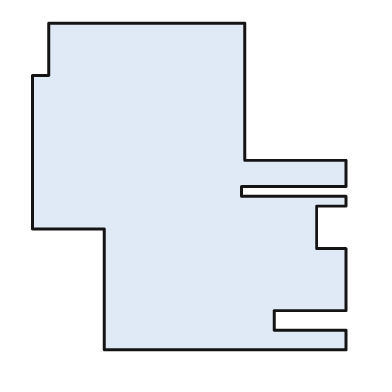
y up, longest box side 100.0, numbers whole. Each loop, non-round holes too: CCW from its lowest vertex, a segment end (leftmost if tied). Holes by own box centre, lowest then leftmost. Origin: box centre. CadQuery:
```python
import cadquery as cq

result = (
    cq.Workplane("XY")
    .moveTo(-26.0, -50.0)
    .lineTo(48.0, -50.0)
    .lineTo(48.0, -44.0)
    .lineTo(26.0, -44.0)
    .lineTo(26.0, -38.0)
    .lineTo(48.0, -38.0)
    .lineTo(48.0, -19.0)
    .lineTo(39.0, -19.0)
    .lineTo(39.0, -6.0)
    .lineTo(48.0, -6.0)
    .lineTo(48.0, -3.0)
    .lineTo(16.0, -3.0)
    .lineTo(16.0, 0.0)
    .lineTo(48.0, 0.0)
    .lineTo(48.0, 8.0)
    .lineTo(17.0, 8.0)
    .lineTo(17.0, 50.0)
    .lineTo(-43.0, 50.0)
    .lineTo(-43.0, 34.0)
    .lineTo(-48.0, 34.0)
    .lineTo(-48.0, -13.0)
    .lineTo(-26.0, -13.0)
    .close()
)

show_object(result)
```